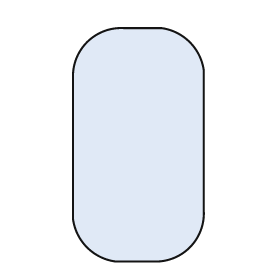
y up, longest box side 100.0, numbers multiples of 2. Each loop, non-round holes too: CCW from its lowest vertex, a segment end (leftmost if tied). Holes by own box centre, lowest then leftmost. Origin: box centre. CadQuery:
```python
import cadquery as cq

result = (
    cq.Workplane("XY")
    .moveTo(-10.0, -50.0)
    .lineTo(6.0, -50.0)
    .threePointArc((22.0, -44.0), (28.0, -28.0))
    .lineTo(28.0, 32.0)
    .threePointArc((22.0, 44.0), (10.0, 50.0))
    .lineTo(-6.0, 50.0)
    .threePointArc((-22.0, 44.0), (-28.0, 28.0))
    .lineTo(-28.0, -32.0)
    .threePointArc((-22.0, -44.0), (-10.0, -50.0))
    .close()
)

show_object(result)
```